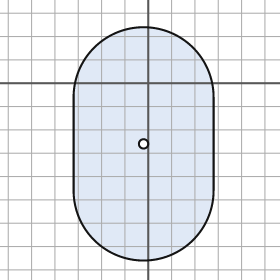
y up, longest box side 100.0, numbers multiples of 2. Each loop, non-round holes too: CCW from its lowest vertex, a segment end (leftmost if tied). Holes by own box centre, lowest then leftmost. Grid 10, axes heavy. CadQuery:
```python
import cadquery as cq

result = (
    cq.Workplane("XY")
    .moveTo(-32.0, -46.0)
    .threePointArc((-2.0, -76.0), (28.0, -46.0))
    .lineTo(28.0, -6.0)
    .threePointArc((-2.0, 24.0), (-32.0, -6.0))
    .close()
    .moveTo(-2.0, -26.0)
    .circle(2.0)
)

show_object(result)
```